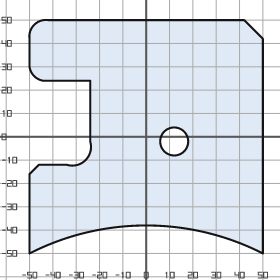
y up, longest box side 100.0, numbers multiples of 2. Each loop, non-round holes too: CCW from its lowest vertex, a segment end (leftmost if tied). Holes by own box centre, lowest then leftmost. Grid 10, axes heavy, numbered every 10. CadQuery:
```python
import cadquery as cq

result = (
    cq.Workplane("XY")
    .moveTo(-50.0, -50.0)
    .threePointArc((0.0, -38.0), (50.0, -50.0))
    .lineTo(50.0, 42.0)
    .lineTo(42.0, 50.0)
    .lineTo(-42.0, 50.0)
    .threePointArc((-48.0, 48.0), (-50.0, 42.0))
    .lineTo(-50.0, 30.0)
    .threePointArc((-48.0, 26.0), (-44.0, 24.0))
    .lineTo(-24.0, 24.0)
    .lineTo(-24.0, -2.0)
    .threePointArc((-26.0, -10.0), (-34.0, -12.0))
    .lineTo(-46.0, -12.0)
    .lineTo(-50.0, -16.0)
    .close()
    .moveTo(12.0, -2.0)
    .circle(6.0)
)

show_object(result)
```